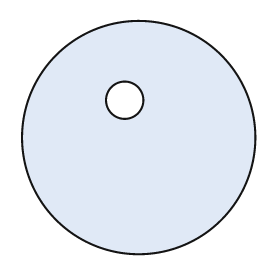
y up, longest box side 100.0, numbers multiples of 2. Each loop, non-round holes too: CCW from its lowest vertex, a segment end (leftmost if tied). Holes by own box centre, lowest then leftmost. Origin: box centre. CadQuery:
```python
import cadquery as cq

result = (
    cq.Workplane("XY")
    .moveTo(0.0, 0.0)
    .circle(50.0)
    .moveTo(-6.0, 16.0)
    .circle(8.0)
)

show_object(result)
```